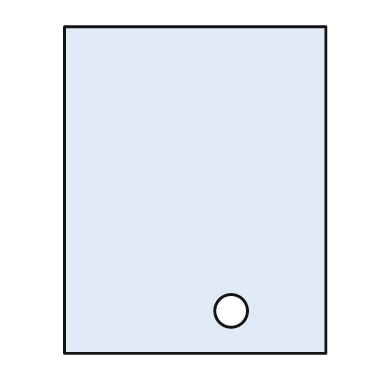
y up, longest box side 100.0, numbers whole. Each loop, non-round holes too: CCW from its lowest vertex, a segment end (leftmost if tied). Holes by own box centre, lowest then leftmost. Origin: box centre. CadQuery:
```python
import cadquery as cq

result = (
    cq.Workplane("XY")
    .moveTo(-40.0, -50.0)
    .lineTo(40.0, -50.0)
    .lineTo(40.0, 50.0)
    .lineTo(-40.0, 50.0)
    .close()
    .moveTo(11.0, -37.0)
    .circle(5.0)
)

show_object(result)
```